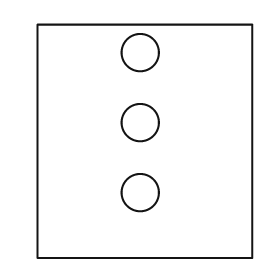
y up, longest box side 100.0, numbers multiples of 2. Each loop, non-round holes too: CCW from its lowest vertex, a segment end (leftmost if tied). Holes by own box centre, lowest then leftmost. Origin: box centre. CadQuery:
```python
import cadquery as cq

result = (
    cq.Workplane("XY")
    .moveTo(-46.0, -50.0)
    .lineTo(46.0, -50.0)
    .lineTo(46.0, 50.0)
    .lineTo(-46.0, 50.0)
    .close()
    .moveTo(-2.0, -22.0)
    .circle(8.0)
    .moveTo(-2.0, 8.0)
    .circle(8.0)
    .moveTo(-2.0, 38.0)
    .circle(8.0)
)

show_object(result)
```